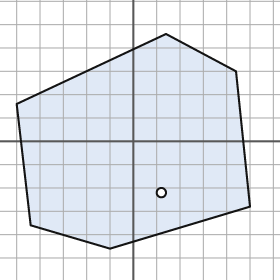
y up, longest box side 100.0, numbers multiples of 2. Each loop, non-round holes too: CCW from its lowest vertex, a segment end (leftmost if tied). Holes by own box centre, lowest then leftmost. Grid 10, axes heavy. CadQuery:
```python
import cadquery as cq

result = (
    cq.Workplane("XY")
    .moveTo(-10.0, -46.0)
    .lineTo(50.0, -28.0)
    .lineTo(44.0, 30.0)
    .lineTo(14.0, 46.0)
    .lineTo(-50.0, 16.0)
    .lineTo(-44.0, -36.0)
    .close()
    .moveTo(12.0, -22.0)
    .circle(2.0)
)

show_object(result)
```